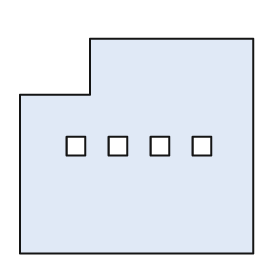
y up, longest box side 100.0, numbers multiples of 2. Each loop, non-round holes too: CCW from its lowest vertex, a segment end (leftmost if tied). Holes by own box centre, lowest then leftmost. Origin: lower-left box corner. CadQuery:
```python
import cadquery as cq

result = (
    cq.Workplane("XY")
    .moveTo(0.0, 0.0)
    .lineTo(100.0, 0.0)
    .lineTo(100.0, 92.0)
    .lineTo(30.0, 92.0)
    .lineTo(30.0, 68.0)
    .lineTo(0.0, 68.0)
    .close()
    .moveTo(20.0, 42.0)
    .lineTo(28.0, 42.0)
    .lineTo(28.0, 50.0)
    .lineTo(20.0, 50.0)
    .close()
    .moveTo(38.0, 42.0)
    .lineTo(46.0, 42.0)
    .lineTo(46.0, 50.0)
    .lineTo(38.0, 50.0)
    .close()
    .moveTo(56.0, 42.0)
    .lineTo(64.0, 42.0)
    .lineTo(64.0, 50.0)
    .lineTo(56.0, 50.0)
    .close()
    .moveTo(74.0, 42.0)
    .lineTo(82.0, 42.0)
    .lineTo(82.0, 50.0)
    .lineTo(74.0, 50.0)
    .close()
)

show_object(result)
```